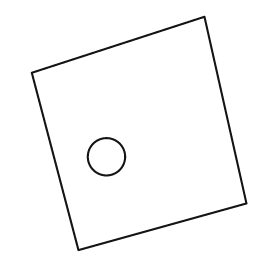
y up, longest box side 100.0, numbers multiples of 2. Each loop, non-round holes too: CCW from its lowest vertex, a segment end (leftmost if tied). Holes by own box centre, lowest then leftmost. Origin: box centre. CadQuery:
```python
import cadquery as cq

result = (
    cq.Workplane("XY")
    .moveTo(-26.0, -50.0)
    .lineTo(46.0, -30.0)
    .lineTo(28.0, 50.0)
    .lineTo(-46.0, 26.0)
    .close()
    .moveTo(-14.0, -10.0)
    .circle(8.0)
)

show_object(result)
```